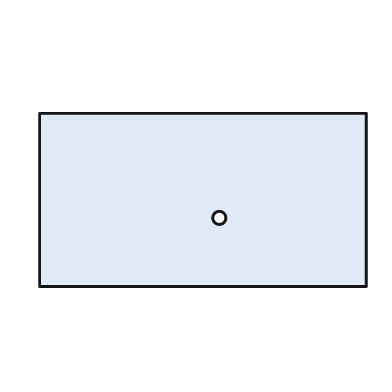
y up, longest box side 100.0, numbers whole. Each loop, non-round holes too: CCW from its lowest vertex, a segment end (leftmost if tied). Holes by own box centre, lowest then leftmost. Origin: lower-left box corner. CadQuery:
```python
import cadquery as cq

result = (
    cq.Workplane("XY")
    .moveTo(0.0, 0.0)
    .lineTo(100.0, 0.0)
    .lineTo(100.0, 53.0)
    .lineTo(0.0, 53.0)
    .close()
    .moveTo(55.0, 21.0)
    .circle(2.0)
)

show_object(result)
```